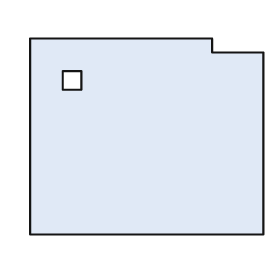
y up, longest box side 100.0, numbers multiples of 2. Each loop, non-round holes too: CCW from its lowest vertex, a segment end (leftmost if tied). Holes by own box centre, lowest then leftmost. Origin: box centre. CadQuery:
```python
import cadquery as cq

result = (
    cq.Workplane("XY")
    .moveTo(-50.0, -42.0)
    .lineTo(50.0, -42.0)
    .lineTo(50.0, 36.0)
    .lineTo(28.0, 36.0)
    .lineTo(28.0, 42.0)
    .lineTo(-50.0, 42.0)
    .close()
    .moveTo(-36.0, 20.0)
    .lineTo(-28.0, 20.0)
    .lineTo(-28.0, 28.0)
    .lineTo(-36.0, 28.0)
    .close()
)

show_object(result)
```